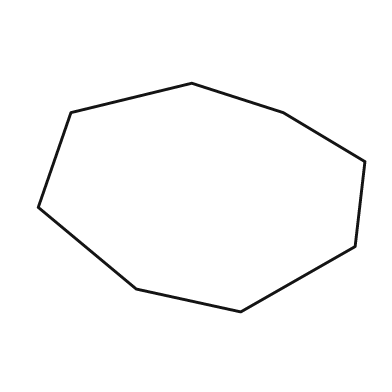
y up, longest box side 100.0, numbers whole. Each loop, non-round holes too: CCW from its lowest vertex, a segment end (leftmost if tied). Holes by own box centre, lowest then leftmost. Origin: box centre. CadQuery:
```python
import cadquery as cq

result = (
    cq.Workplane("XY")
    .moveTo(12.0, -35.0)
    .lineTo(47.0, -15.0)
    .lineTo(50.0, 11.0)
    .lineTo(25.0, 26.0)
    .lineTo(-3.0, 35.0)
    .lineTo(-40.0, 26.0)
    .lineTo(-50.0, -3.0)
    .lineTo(-20.0, -28.0)
    .close()
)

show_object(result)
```